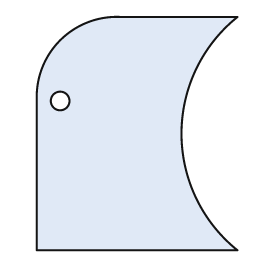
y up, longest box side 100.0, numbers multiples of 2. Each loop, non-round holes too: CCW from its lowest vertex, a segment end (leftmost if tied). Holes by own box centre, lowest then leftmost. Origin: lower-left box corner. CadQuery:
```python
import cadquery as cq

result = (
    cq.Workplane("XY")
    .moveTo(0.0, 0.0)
    .lineTo(86.0, 0.0)
    .threePointArc((62.0, 50.0), (86.0, 100.0))
    .lineTo(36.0, 100.0)
    .threePointArc((10.0, 90.0), (0.0, 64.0))
    .close()
    .moveTo(10.0, 64.0)
    .circle(4.0)
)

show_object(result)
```